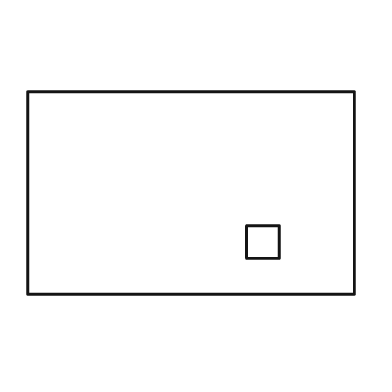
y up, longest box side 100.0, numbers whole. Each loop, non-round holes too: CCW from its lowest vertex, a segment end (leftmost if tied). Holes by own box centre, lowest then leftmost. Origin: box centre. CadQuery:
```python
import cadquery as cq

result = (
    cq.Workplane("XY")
    .moveTo(-50.0, -31.0)
    .lineTo(50.0, -31.0)
    .lineTo(50.0, 31.0)
    .lineTo(-50.0, 31.0)
    .close()
    .moveTo(17.0, -20.0)
    .lineTo(27.0, -20.0)
    .lineTo(27.0, -10.0)
    .lineTo(17.0, -10.0)
    .close()
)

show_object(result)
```